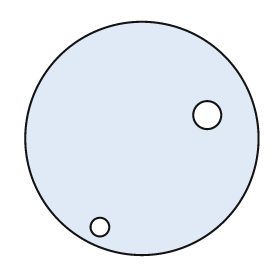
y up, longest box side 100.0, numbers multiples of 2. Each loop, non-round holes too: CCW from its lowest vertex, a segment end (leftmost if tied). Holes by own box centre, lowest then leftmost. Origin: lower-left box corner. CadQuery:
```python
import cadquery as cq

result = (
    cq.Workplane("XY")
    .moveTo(50.0, 50.0)
    .circle(50.0)
    .moveTo(32.0, 12.0)
    .circle(4.0)
    .moveTo(78.0, 60.0)
    .circle(6.0)
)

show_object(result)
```